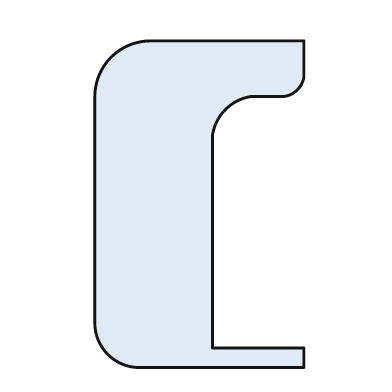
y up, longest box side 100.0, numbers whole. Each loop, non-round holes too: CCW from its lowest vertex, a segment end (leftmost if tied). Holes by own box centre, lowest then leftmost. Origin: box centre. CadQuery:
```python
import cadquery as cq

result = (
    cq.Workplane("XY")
    .moveTo(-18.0, -50.0)
    .lineTo(32.0, -50.0)
    .lineTo(32.0, -44.0)
    .lineTo(4.0, -44.0)
    .lineTo(4.0, 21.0)
    .threePointArc((8.0, 29.0), (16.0, 33.0))
    .lineTo(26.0, 33.0)
    .threePointArc((30.0, 35.0), (32.0, 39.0))
    .lineTo(32.0, 50.0)
    .lineTo(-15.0, 50.0)
    .threePointArc((-27.0, 45.0), (-32.0, 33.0))
    .lineTo(-32.0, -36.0)
    .threePointArc((-28.0, -46.0), (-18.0, -50.0))
    .close()
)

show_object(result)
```